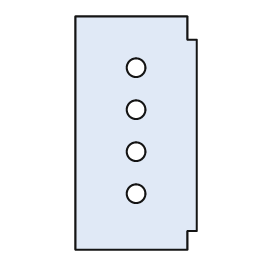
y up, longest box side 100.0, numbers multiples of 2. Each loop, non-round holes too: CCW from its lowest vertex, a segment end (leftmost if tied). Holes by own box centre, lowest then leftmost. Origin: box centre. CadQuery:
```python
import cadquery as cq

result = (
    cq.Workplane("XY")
    .moveTo(-26.0, -50.0)
    .lineTo(22.0, -50.0)
    .lineTo(22.0, -42.0)
    .lineTo(26.0, -42.0)
    .lineTo(26.0, 40.0)
    .lineTo(22.0, 40.0)
    .lineTo(22.0, 50.0)
    .lineTo(-26.0, 50.0)
    .close()
    .moveTo(0.0, -26.0)
    .circle(4.0)
    .moveTo(0.0, -8.0)
    .circle(4.0)
    .moveTo(0.0, 10.0)
    .circle(4.0)
    .moveTo(0.0, 28.0)
    .circle(4.0)
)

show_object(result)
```